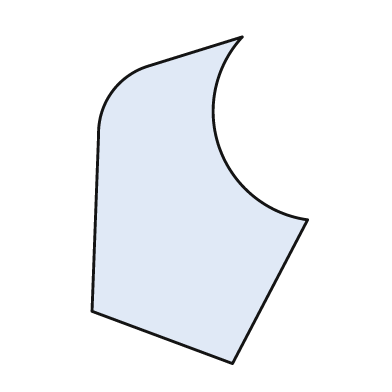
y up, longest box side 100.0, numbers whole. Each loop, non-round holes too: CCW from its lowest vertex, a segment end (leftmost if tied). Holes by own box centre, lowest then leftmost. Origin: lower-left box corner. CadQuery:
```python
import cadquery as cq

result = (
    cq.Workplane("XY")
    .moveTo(43.0, 0.0)
    .lineTo(66.0, 44.0)
    .threePointArc((39.0, 66.0), (46.0, 100.0))
    .lineTo(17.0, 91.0)
    .threePointArc((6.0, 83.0), (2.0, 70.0))
    .lineTo(0.0, 16.0)
    .close()
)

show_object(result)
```